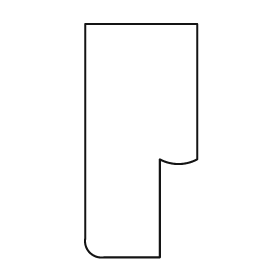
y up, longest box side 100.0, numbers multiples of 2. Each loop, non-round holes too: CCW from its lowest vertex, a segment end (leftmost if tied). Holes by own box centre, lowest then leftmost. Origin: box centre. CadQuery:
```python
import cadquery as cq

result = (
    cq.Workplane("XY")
    .moveTo(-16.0, -50.0)
    .lineTo(8.0, -50.0)
    .lineTo(8.0, -8.0)
    .threePointArc((16.0, -10.0), (24.0, -8.0))
    .lineTo(24.0, 50.0)
    .lineTo(-24.0, 50.0)
    .lineTo(-24.0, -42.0)
    .threePointArc((-22.0, -48.0), (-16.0, -50.0))
    .close()
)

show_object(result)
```